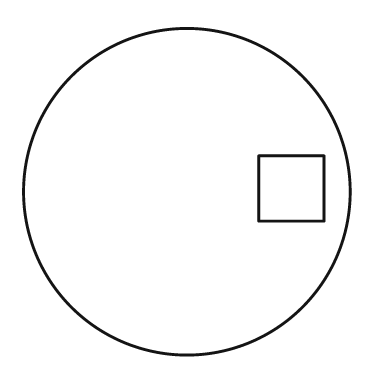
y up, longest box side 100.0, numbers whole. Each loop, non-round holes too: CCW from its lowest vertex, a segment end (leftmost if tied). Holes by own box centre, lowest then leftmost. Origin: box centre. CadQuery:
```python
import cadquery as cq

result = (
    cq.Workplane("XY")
    .moveTo(0.0, 0.0)
    .circle(50.0)
    .moveTo(22.0, -9.0)
    .lineTo(42.0, -9.0)
    .lineTo(42.0, 11.0)
    .lineTo(22.0, 11.0)
    .close()
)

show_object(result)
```